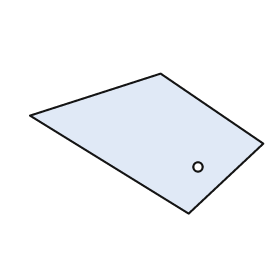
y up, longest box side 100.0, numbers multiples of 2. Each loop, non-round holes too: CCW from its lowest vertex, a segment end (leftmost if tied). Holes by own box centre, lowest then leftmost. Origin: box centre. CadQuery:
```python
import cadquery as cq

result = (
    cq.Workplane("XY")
    .moveTo(18.0, -30.0)
    .lineTo(50.0, 0.0)
    .lineTo(6.0, 30.0)
    .lineTo(-50.0, 12.0)
    .close()
    .moveTo(22.0, -10.0)
    .circle(2.0)
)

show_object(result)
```